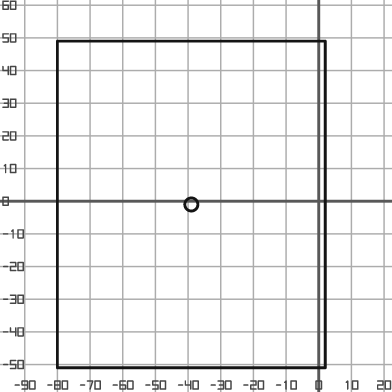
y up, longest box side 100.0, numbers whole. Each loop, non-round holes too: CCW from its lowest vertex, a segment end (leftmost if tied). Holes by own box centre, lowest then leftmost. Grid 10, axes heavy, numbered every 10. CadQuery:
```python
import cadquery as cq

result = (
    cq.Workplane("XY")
    .moveTo(-80.0, -51.0)
    .lineTo(2.0, -51.0)
    .lineTo(2.0, 49.0)
    .lineTo(-80.0, 49.0)
    .close()
    .moveTo(-39.0, -1.0)
    .circle(2.0)
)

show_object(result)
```